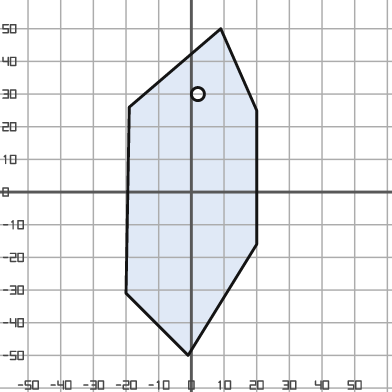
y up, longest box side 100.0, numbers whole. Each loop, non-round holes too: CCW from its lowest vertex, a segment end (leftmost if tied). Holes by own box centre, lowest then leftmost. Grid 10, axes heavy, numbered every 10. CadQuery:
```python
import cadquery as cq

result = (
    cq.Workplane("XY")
    .moveTo(-1.0, -50.0)
    .lineTo(20.0, -16.0)
    .lineTo(20.0, 25.0)
    .lineTo(9.0, 50.0)
    .lineTo(-19.0, 26.0)
    .lineTo(-20.0, -31.0)
    .close()
    .moveTo(2.0, 30.0)
    .circle(2.0)
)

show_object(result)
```